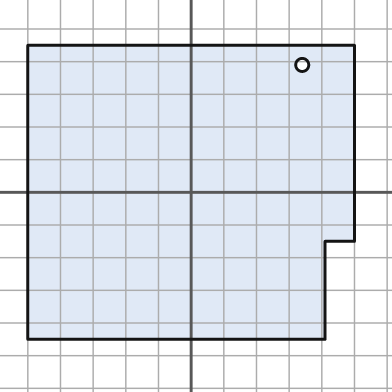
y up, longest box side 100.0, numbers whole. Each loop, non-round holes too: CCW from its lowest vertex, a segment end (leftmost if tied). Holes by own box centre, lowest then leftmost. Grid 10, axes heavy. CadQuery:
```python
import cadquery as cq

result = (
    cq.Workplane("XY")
    .moveTo(-50.0, -45.0)
    .lineTo(41.0, -45.0)
    .lineTo(41.0, -15.0)
    .lineTo(50.0, -15.0)
    .lineTo(50.0, 45.0)
    .lineTo(-50.0, 45.0)
    .close()
    .moveTo(34.0, 39.0)
    .circle(2.0)
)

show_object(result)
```